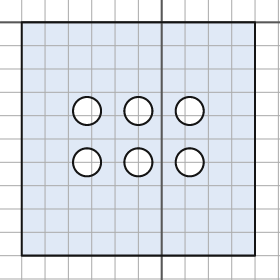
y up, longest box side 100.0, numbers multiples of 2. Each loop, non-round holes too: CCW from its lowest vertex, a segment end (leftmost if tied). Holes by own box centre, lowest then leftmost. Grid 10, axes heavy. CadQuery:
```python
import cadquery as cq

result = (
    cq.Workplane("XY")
    .moveTo(-60.0, -100.0)
    .lineTo(40.0, -100.0)
    .lineTo(40.0, 0.0)
    .lineTo(-60.0, 0.0)
    .close()
    .moveTo(-32.0, -60.0)
    .circle(6.0)
    .moveTo(-10.0, -60.0)
    .circle(6.0)
    .moveTo(12.0, -60.0)
    .circle(6.0)
    .moveTo(-32.0, -38.0)
    .circle(6.0)
    .moveTo(-10.0, -38.0)
    .circle(6.0)
    .moveTo(12.0, -38.0)
    .circle(6.0)
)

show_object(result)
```